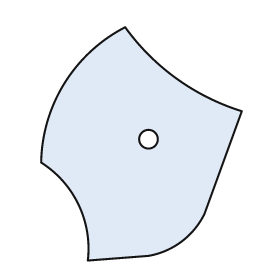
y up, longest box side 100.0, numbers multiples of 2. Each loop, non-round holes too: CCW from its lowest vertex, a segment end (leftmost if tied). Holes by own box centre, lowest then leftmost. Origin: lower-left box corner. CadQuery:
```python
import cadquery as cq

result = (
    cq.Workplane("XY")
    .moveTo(20.0, 0.0)
    .lineTo(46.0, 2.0)
    .threePointArc((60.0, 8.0), (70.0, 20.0))
    .lineTo(86.0, 64.0)
    .threePointArc((58.0, 78.0), (36.0, 100.0))
    .threePointArc((10.0, 76.0), (0.0, 42.0))
    .threePointArc((16.0, 24.0), (20.0, 0.0))
    .close()
    .moveTo(46.0, 52.0)
    .circle(4.0)
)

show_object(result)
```